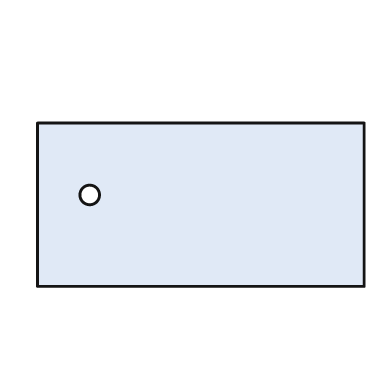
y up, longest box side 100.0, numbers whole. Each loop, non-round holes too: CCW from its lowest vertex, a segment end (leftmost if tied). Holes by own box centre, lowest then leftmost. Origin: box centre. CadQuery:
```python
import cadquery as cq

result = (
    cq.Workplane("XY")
    .moveTo(-50.0, -25.0)
    .lineTo(50.0, -25.0)
    .lineTo(50.0, 25.0)
    .lineTo(-50.0, 25.0)
    .close()
    .moveTo(-34.0, 3.0)
    .circle(3.0)
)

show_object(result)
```